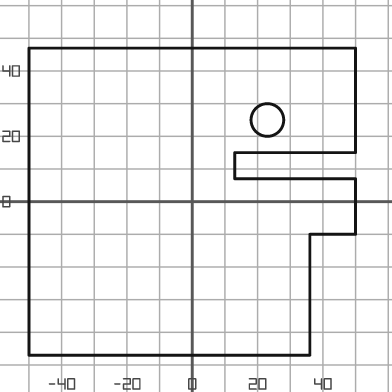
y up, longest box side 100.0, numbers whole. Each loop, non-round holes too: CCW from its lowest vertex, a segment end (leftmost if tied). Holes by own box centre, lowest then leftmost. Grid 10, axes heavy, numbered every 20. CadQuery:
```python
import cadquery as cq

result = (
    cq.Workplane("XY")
    .moveTo(-50.0, -47.0)
    .lineTo(36.0, -47.0)
    .lineTo(36.0, -10.0)
    .lineTo(50.0, -10.0)
    .lineTo(50.0, 7.0)
    .lineTo(13.0, 7.0)
    .lineTo(13.0, 15.0)
    .lineTo(50.0, 15.0)
    .lineTo(50.0, 47.0)
    .lineTo(-50.0, 47.0)
    .close()
    .moveTo(23.0, 25.0)
    .circle(5.0)
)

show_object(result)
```